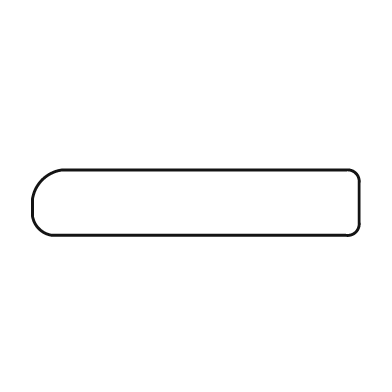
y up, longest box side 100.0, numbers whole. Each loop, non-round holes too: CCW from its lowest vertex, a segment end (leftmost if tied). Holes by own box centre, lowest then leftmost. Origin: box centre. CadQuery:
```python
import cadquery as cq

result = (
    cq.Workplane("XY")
    .moveTo(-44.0, -10.0)
    .lineTo(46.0, -10.0)
    .threePointArc((49.0, -9.0), (50.0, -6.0))
    .lineTo(50.0, 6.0)
    .threePointArc((49.0, 9.0), (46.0, 10.0))
    .lineTo(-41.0, 10.0)
    .threePointArc((-47.0, 7.0), (-50.0, 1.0))
    .lineTo(-50.0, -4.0)
    .threePointArc((-48.0, -8.0), (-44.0, -10.0))
    .close()
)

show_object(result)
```